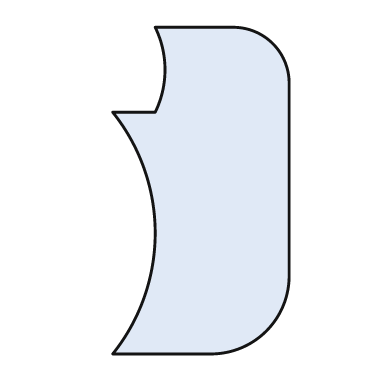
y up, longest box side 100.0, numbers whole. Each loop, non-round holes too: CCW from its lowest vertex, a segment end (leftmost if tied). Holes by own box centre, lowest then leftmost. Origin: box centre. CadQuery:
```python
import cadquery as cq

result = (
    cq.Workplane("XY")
    .moveTo(-27.0, -50.0)
    .lineTo(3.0, -50.0)
    .threePointArc((20.0, -43.0), (27.0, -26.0))
    .lineTo(27.0, 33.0)
    .threePointArc((22.0, 45.0), (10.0, 50.0))
    .lineTo(-14.0, 50.0)
    .threePointArc((-11.0, 37.0), (-14.0, 24.0))
    .lineTo(-27.0, 24.0)
    .threePointArc((-14.0, -13.0), (-27.0, -50.0))
    .close()
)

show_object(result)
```